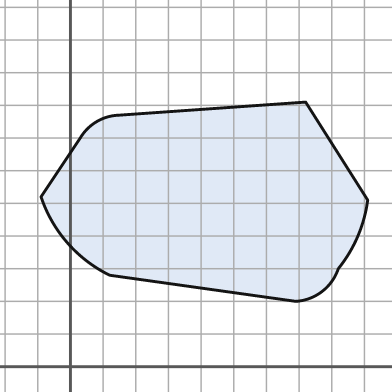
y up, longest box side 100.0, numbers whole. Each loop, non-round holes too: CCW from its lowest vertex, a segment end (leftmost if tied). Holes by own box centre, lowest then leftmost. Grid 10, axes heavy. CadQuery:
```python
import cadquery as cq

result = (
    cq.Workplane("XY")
    .moveTo(69.0, 20.0)
    .threePointArc((77.0, 23.0), (82.0, 30.0))
    .threePointArc((88.0, 40.0), (91.0, 51.0))
    .lineTo(72.0, 81.0)
    .lineTo(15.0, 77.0)
    .threePointArc((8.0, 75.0), (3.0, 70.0))
    .lineTo(-9.0, 52.0)
    .threePointArc((-1.0, 38.0), (12.0, 28.0))
    .close()
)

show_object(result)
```